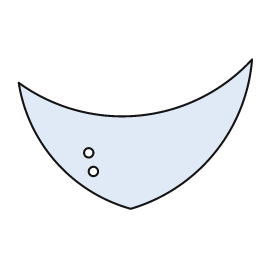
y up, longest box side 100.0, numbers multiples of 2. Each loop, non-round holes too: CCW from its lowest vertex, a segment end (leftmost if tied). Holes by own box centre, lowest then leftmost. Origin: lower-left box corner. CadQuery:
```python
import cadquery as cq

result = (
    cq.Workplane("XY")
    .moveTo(48.0, 0.0)
    .threePointArc((84.0, 24.0), (100.0, 64.0))
    .threePointArc((52.0, 40.0), (0.0, 54.0))
    .threePointArc((16.0, 20.0), (48.0, 0.0))
    .close()
    .moveTo(32.0, 16.0)
    .circle(2.0)
    .moveTo(30.0, 24.0)
    .circle(2.0)
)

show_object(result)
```